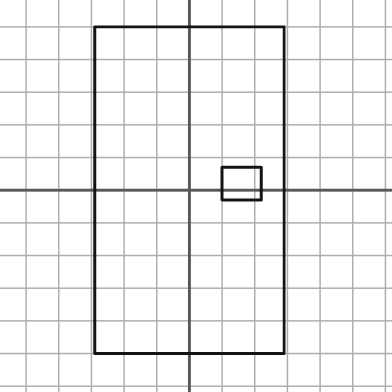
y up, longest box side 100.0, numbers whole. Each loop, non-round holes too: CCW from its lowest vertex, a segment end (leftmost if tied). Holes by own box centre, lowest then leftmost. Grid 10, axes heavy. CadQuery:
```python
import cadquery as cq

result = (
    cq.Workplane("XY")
    .moveTo(-29.0, -50.0)
    .lineTo(29.0, -50.0)
    .lineTo(29.0, 50.0)
    .lineTo(-29.0, 50.0)
    .close()
    .moveTo(10.0, -3.0)
    .lineTo(22.0, -3.0)
    .lineTo(22.0, 7.0)
    .lineTo(10.0, 7.0)
    .close()
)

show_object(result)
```